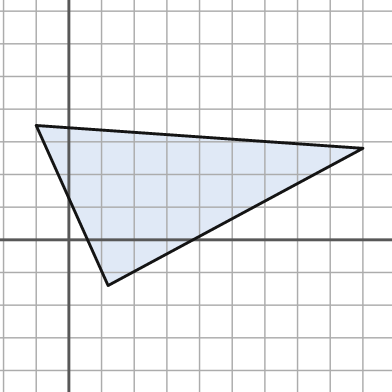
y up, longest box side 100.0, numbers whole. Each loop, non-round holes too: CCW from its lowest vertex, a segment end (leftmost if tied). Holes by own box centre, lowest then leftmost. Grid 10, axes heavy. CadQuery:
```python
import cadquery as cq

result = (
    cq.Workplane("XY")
    .moveTo(12.0, -14.0)
    .lineTo(90.0, 28.0)
    .lineTo(-10.0, 35.0)
    .close()
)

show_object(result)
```